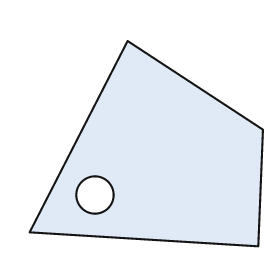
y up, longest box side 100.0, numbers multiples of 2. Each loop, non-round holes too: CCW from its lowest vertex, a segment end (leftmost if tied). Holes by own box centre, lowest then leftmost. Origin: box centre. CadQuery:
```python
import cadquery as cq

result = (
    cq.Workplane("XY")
    .moveTo(48.0, -44.0)
    .lineTo(50.0, 6.0)
    .lineTo(-8.0, 44.0)
    .lineTo(-50.0, -38.0)
    .close()
    .moveTo(-22.0, -22.0)
    .circle(8.0)
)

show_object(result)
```